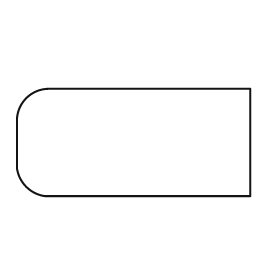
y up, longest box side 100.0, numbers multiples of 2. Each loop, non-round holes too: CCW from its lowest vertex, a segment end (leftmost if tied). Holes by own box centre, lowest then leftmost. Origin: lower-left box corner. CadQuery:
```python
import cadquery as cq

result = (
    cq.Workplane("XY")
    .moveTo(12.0, 0.0)
    .lineTo(100.0, 0.0)
    .lineTo(100.0, 46.0)
    .lineTo(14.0, 46.0)
    .threePointArc((4.0, 42.0), (0.0, 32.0))
    .lineTo(0.0, 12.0)
    .threePointArc((4.0, 4.0), (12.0, 0.0))
    .close()
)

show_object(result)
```